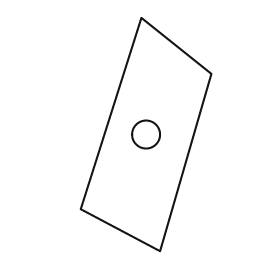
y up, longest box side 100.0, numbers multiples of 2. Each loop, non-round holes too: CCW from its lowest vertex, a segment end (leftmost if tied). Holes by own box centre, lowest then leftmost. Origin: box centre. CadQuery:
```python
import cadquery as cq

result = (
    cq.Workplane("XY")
    .moveTo(6.0, -50.0)
    .lineTo(28.0, 26.0)
    .lineTo(-2.0, 50.0)
    .lineTo(-28.0, -32.0)
    .close()
    .moveTo(0.0, 0.0)
    .circle(6.0)
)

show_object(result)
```